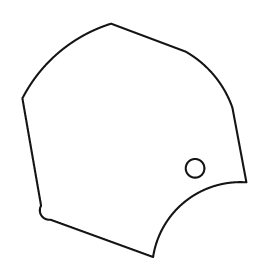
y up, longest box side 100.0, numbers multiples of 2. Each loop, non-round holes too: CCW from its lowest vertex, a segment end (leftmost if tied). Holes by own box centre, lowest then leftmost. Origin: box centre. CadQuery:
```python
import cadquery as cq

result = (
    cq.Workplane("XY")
    .moveTo(8.0, -50.0)
    .threePointArc((22.0, -26.0), (48.0, -18.0))
    .lineTo(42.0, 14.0)
    .threePointArc((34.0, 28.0), (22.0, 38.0))
    .lineTo(-10.0, 50.0)
    .threePointArc((-32.0, 38.0), (-48.0, 18.0))
    .lineTo(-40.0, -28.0)
    .threePointArc((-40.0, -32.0), (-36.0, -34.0))
    .close()
    .moveTo(26.0, -12.0)
    .circle(4.0)
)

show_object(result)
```